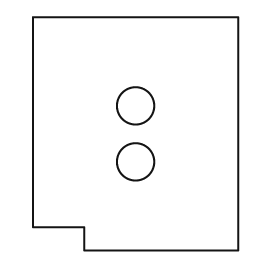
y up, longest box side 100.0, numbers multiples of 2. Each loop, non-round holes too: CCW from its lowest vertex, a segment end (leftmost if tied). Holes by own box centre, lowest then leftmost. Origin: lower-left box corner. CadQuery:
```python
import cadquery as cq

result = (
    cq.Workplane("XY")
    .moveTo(22.0, 0.0)
    .lineTo(88.0, 0.0)
    .lineTo(88.0, 100.0)
    .lineTo(0.0, 100.0)
    .lineTo(0.0, 10.0)
    .lineTo(22.0, 10.0)
    .close()
    .moveTo(44.0, 38.0)
    .circle(8.0)
    .moveTo(44.0, 62.0)
    .circle(8.0)
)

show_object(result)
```